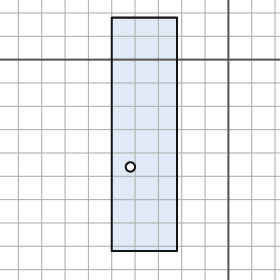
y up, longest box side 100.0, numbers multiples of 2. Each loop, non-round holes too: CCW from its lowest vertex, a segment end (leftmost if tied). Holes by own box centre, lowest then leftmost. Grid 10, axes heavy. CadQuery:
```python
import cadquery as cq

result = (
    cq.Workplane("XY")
    .moveTo(-50.0, -82.0)
    .lineTo(-22.0, -82.0)
    .lineTo(-22.0, 18.0)
    .lineTo(-50.0, 18.0)
    .close()
    .moveTo(-42.0, -46.0)
    .circle(2.0)
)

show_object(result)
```